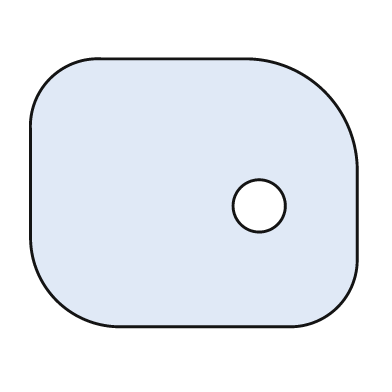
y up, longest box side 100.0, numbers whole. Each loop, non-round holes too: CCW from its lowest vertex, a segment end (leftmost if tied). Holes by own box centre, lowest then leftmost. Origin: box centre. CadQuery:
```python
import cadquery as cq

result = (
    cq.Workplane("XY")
    .moveTo(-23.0, -41.0)
    .lineTo(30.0, -41.0)
    .threePointArc((44.0, -35.0), (50.0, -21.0))
    .lineTo(50.0, 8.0)
    .threePointArc((40.0, 31.0), (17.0, 41.0))
    .lineTo(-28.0, 41.0)
    .threePointArc((-44.0, 35.0), (-50.0, 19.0))
    .lineTo(-50.0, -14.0)
    .threePointArc((-42.0, -33.0), (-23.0, -41.0))
    .close()
    .moveTo(20.0, -4.0)
    .circle(8.0)
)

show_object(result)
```